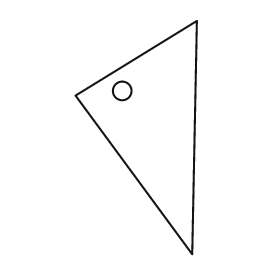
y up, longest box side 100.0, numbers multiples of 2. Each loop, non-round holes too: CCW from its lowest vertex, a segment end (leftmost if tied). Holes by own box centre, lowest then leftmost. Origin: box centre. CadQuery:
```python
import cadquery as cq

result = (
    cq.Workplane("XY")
    .moveTo(24.0, -50.0)
    .lineTo(26.0, 50.0)
    .lineTo(-26.0, 18.0)
    .close()
    .moveTo(-6.0, 20.0)
    .circle(4.0)
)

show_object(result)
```